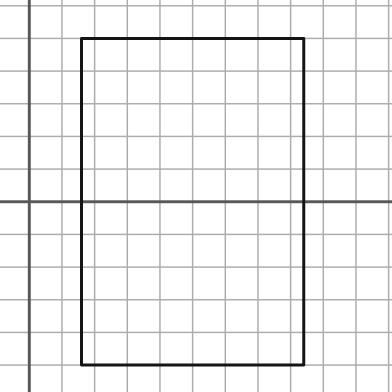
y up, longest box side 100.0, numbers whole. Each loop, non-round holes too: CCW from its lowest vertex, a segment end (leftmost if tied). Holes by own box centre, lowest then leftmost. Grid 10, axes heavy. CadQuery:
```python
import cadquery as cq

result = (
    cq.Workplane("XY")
    .moveTo(16.0, -50.0)
    .lineTo(84.0, -50.0)
    .lineTo(84.0, 50.0)
    .lineTo(16.0, 50.0)
    .close()
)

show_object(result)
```